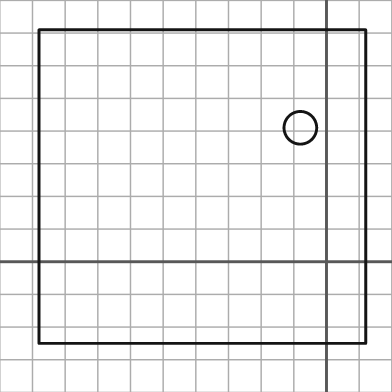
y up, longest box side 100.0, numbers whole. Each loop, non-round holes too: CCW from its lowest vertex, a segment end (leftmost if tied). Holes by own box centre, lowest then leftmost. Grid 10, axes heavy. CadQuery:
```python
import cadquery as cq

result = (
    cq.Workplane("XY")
    .moveTo(-88.0, -25.0)
    .lineTo(12.0, -25.0)
    .lineTo(12.0, 71.0)
    .lineTo(-88.0, 71.0)
    .close()
    .moveTo(-8.0, 41.0)
    .circle(5.0)
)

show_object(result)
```